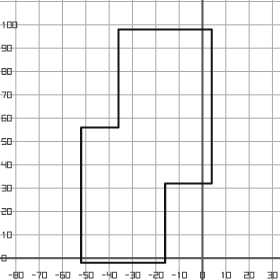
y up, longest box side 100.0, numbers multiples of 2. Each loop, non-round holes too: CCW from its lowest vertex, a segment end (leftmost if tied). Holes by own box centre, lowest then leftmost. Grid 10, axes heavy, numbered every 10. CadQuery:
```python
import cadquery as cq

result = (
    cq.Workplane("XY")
    .moveTo(-52.0, -2.0)
    .lineTo(-16.0, -2.0)
    .lineTo(-16.0, 32.0)
    .lineTo(4.0, 32.0)
    .lineTo(4.0, 98.0)
    .lineTo(-36.0, 98.0)
    .lineTo(-36.0, 56.0)
    .lineTo(-52.0, 56.0)
    .close()
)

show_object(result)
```